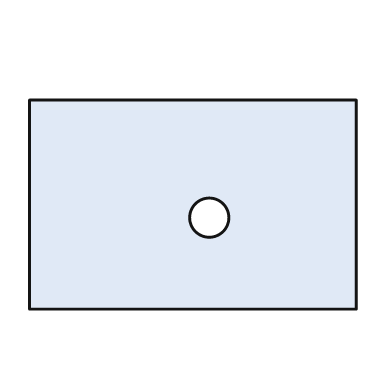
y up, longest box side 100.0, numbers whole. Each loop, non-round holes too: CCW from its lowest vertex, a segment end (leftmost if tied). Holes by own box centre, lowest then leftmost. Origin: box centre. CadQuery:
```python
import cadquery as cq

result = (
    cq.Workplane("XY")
    .moveTo(-50.0, -32.0)
    .lineTo(50.0, -32.0)
    .lineTo(50.0, 32.0)
    .lineTo(-50.0, 32.0)
    .close()
    .moveTo(5.0, -4.0)
    .circle(6.0)
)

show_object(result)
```